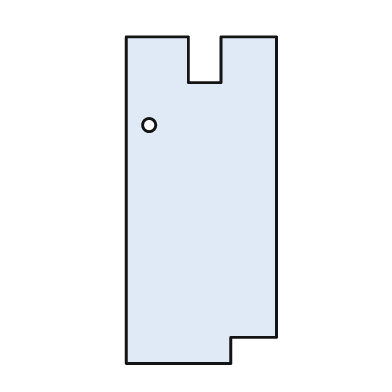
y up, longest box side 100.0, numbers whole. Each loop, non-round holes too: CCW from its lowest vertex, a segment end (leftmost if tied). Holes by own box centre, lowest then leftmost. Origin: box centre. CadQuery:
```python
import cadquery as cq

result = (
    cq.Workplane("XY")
    .moveTo(-23.0, -50.0)
    .lineTo(9.0, -50.0)
    .lineTo(9.0, -42.0)
    .lineTo(23.0, -42.0)
    .lineTo(23.0, 50.0)
    .lineTo(6.0, 50.0)
    .lineTo(6.0, 36.0)
    .lineTo(-4.0, 36.0)
    .lineTo(-4.0, 50.0)
    .lineTo(-23.0, 50.0)
    .close()
    .moveTo(-16.0, 23.0)
    .circle(2.0)
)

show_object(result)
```